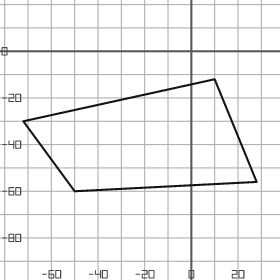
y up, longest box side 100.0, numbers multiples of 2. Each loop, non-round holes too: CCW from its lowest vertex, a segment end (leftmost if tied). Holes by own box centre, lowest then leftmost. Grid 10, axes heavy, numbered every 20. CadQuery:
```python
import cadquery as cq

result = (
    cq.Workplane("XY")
    .moveTo(-50.0, -60.0)
    .lineTo(28.0, -56.0)
    .lineTo(10.0, -12.0)
    .lineTo(-72.0, -30.0)
    .close()
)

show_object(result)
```